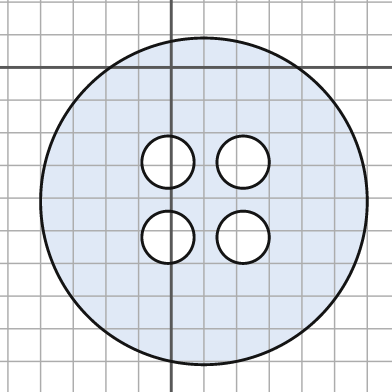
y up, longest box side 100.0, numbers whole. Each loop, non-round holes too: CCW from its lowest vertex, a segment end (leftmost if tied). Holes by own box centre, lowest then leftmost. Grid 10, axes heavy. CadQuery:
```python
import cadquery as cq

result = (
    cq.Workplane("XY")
    .moveTo(10.0, -41.0)
    .circle(50.0)
    .moveTo(-1.0, -52.0)
    .circle(8.0)
    .moveTo(22.0, -52.0)
    .circle(8.0)
    .moveTo(-1.0, -29.0)
    .circle(8.0)
    .moveTo(22.0, -29.0)
    .circle(8.0)
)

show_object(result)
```